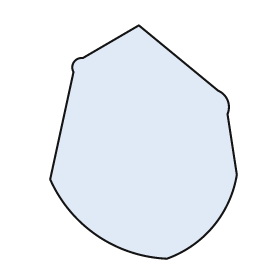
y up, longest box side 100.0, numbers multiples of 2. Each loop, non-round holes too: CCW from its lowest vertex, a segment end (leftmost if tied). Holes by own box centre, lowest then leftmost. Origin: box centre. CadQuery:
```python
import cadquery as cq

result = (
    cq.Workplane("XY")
    .moveTo(10.0, -50.0)
    .threePointArc((30.0, -36.0), (40.0, -14.0))
    .lineTo(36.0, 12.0)
    .threePointArc((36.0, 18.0), (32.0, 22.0))
    .lineTo(-2.0, 50.0)
    .lineTo(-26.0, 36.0)
    .threePointArc((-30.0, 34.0), (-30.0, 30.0))
    .lineTo(-40.0, -16.0)
    .threePointArc((-20.0, -40.0), (10.0, -50.0))
    .close()
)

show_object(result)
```